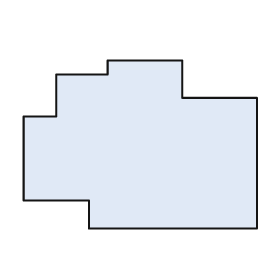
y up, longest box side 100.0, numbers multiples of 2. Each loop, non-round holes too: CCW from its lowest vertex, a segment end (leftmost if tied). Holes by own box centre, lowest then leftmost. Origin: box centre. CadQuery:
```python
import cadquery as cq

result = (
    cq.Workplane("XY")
    .moveTo(-22.0, -36.0)
    .lineTo(50.0, -36.0)
    .lineTo(50.0, 20.0)
    .lineTo(18.0, 20.0)
    .lineTo(18.0, 36.0)
    .lineTo(-14.0, 36.0)
    .lineTo(-14.0, 30.0)
    .lineTo(-36.0, 30.0)
    .lineTo(-36.0, 12.0)
    .lineTo(-50.0, 12.0)
    .lineTo(-50.0, -24.0)
    .lineTo(-22.0, -24.0)
    .close()
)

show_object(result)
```